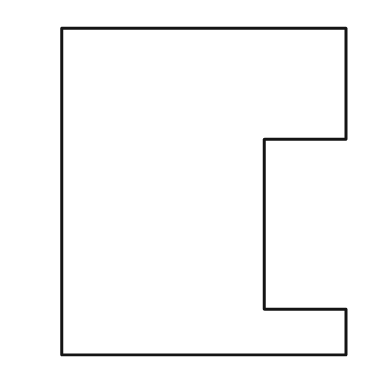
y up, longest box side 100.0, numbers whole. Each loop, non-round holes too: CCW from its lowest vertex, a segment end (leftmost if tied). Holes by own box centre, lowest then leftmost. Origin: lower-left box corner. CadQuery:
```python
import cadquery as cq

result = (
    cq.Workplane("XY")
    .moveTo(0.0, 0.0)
    .lineTo(87.0, 0.0)
    .lineTo(87.0, 14.0)
    .lineTo(62.0, 14.0)
    .lineTo(62.0, 66.0)
    .lineTo(87.0, 66.0)
    .lineTo(87.0, 100.0)
    .lineTo(0.0, 100.0)
    .close()
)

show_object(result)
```